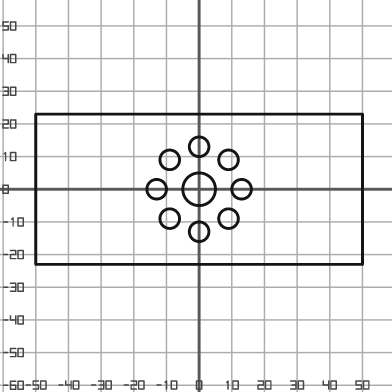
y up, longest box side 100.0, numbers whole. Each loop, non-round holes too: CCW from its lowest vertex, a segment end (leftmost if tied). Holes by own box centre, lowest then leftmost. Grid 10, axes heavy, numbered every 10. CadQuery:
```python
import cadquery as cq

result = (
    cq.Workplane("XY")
    .moveTo(-50.0, -23.0)
    .lineTo(50.0, -23.0)
    .lineTo(50.0, 23.0)
    .lineTo(-50.0, 23.0)
    .close()
    .moveTo(0.0, -13.0)
    .circle(3.0)
    .moveTo(-9.0, -9.0)
    .circle(3.0)
    .moveTo(9.0, -9.0)
    .circle(3.0)
    .moveTo(-13.0, 0.0)
    .circle(3.0)
    .moveTo(0.0, 0.0)
    .circle(5.0)
    .moveTo(13.0, 0.0)
    .circle(3.0)
    .moveTo(-9.0, 9.0)
    .circle(3.0)
    .moveTo(9.0, 9.0)
    .circle(3.0)
    .moveTo(0.0, 13.0)
    .circle(3.0)
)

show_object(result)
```